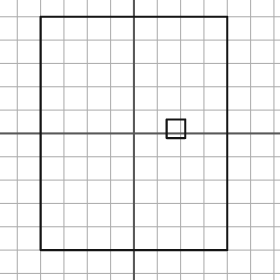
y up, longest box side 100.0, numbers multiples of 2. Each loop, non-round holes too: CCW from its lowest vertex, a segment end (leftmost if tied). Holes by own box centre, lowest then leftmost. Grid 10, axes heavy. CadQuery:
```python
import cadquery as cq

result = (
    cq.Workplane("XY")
    .moveTo(-40.0, -50.0)
    .lineTo(40.0, -50.0)
    .lineTo(40.0, 50.0)
    .lineTo(-40.0, 50.0)
    .close()
    .moveTo(14.0, -2.0)
    .lineTo(22.0, -2.0)
    .lineTo(22.0, 6.0)
    .lineTo(14.0, 6.0)
    .close()
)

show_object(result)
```